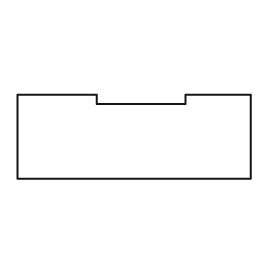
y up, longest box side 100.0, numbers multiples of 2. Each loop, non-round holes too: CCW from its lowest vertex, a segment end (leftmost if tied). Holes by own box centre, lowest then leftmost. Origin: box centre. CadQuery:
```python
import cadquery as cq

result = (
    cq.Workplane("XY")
    .moveTo(-50.0, -18.0)
    .lineTo(50.0, -18.0)
    .lineTo(50.0, 18.0)
    .lineTo(22.0, 18.0)
    .lineTo(22.0, 14.0)
    .lineTo(-16.0, 14.0)
    .lineTo(-16.0, 18.0)
    .lineTo(-50.0, 18.0)
    .close()
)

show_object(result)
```